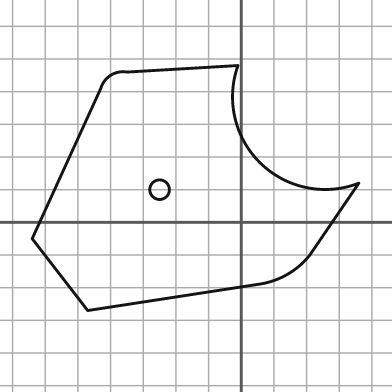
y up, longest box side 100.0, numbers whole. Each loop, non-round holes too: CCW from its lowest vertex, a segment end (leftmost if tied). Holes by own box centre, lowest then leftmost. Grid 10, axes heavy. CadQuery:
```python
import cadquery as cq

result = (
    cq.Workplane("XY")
    .moveTo(-47.0, -27.0)
    .lineTo(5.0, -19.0)
    .threePointArc((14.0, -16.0), (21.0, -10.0))
    .lineTo(36.0, 12.0)
    .threePointArc((6.0, 18.0), (-1.0, 48.0))
    .lineTo(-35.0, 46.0)
    .threePointArc((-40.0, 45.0), (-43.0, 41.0))
    .lineTo(-64.0, -5.0)
    .close()
    .moveTo(-25.0, 10.0)
    .circle(3.0)
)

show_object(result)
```